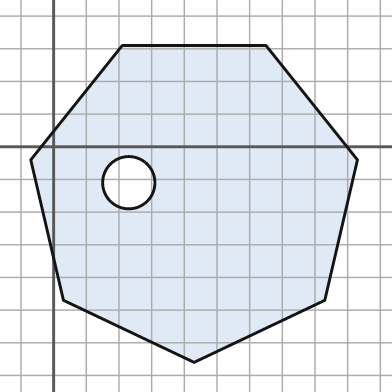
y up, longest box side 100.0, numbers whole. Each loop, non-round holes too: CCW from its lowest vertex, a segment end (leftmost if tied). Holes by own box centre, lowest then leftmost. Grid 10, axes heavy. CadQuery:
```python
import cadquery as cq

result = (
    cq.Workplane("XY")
    .moveTo(43.0, -66.0)
    .lineTo(83.0, -47.0)
    .lineTo(93.0, -4.0)
    .lineTo(65.0, 31.0)
    .lineTo(21.0, 31.0)
    .lineTo(-7.0, -4.0)
    .lineTo(3.0, -47.0)
    .close()
    .moveTo(23.0, -11.0)
    .circle(8.0)
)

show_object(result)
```